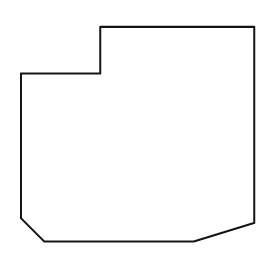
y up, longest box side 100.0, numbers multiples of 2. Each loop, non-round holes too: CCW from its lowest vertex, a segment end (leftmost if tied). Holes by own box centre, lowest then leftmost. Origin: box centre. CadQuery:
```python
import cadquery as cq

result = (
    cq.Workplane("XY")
    .moveTo(-40.0, -46.0)
    .lineTo(24.0, -46.0)
    .lineTo(50.0, -38.0)
    .lineTo(50.0, 46.0)
    .lineTo(-16.0, 46.0)
    .lineTo(-16.0, 26.0)
    .lineTo(-50.0, 26.0)
    .lineTo(-50.0, -36.0)
    .close()
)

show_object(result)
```